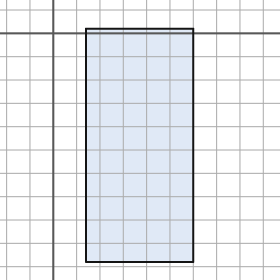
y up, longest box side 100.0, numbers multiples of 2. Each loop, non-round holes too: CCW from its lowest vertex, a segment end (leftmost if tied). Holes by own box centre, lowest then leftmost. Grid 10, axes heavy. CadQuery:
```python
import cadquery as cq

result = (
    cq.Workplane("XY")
    .moveTo(14.0, -98.0)
    .lineTo(60.0, -98.0)
    .lineTo(60.0, 2.0)
    .lineTo(14.0, 2.0)
    .close()
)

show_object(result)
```